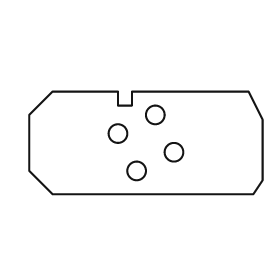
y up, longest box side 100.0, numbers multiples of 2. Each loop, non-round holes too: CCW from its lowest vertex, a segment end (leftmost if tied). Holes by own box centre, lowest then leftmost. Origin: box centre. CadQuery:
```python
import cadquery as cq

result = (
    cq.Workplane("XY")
    .moveTo(-40.0, -22.0)
    .lineTo(46.0, -22.0)
    .lineTo(50.0, -16.0)
    .lineTo(50.0, 10.0)
    .lineTo(44.0, 22.0)
    .lineTo(-6.0, 22.0)
    .lineTo(-6.0, 16.0)
    .lineTo(-12.0, 16.0)
    .lineTo(-12.0, 22.0)
    .lineTo(-40.0, 22.0)
    .lineTo(-50.0, 12.0)
    .lineTo(-50.0, -12.0)
    .close()
    .moveTo(-4.0, -12.0)
    .circle(4.0)
    .moveTo(12.0, -4.0)
    .circle(4.0)
    .moveTo(-12.0, 4.0)
    .circle(4.0)
    .moveTo(4.0, 12.0)
    .circle(4.0)
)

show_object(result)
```